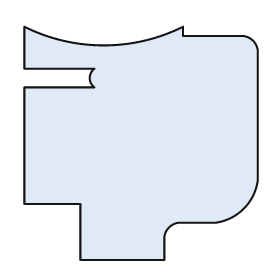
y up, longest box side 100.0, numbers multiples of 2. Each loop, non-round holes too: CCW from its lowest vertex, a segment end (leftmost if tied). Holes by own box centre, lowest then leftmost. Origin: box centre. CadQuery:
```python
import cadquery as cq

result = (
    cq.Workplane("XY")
    .moveTo(-26.0, -50.0)
    .lineTo(10.0, -50.0)
    .lineTo(10.0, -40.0)
    .threePointArc((12.0, -36.0), (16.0, -34.0))
    .lineTo(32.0, -34.0)
    .threePointArc((44.0, -28.0), (50.0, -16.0))
    .lineTo(50.0, 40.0)
    .threePointArc((48.0, 44.0), (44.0, 46.0))
    .lineTo(18.0, 46.0)
    .lineTo(18.0, 50.0)
    .threePointArc((-16.0, 42.0), (-50.0, 50.0))
    .lineTo(-50.0, 32.0)
    .lineTo(-20.0, 32.0)
    .threePointArc((-22.0, 28.0), (-20.0, 24.0))
    .lineTo(-50.0, 24.0)
    .lineTo(-50.0, -26.0)
    .lineTo(-26.0, -26.0)
    .close()
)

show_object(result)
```